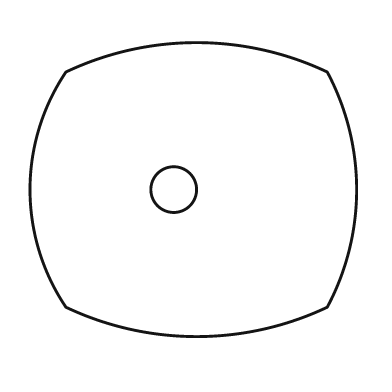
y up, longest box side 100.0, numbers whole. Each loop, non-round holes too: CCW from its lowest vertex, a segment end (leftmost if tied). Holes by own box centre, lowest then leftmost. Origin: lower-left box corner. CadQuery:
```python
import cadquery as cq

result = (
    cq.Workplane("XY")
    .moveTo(11.0, 9.0)
    .threePointArc((51.0, 0.0), (91.0, 9.0))
    .threePointArc((100.0, 45.0), (91.0, 81.0))
    .threePointArc((51.0, 90.0), (11.0, 81.0))
    .threePointArc((0.0, 45.0), (11.0, 9.0))
    .close()
    .moveTo(44.0, 45.0)
    .circle(7.0)
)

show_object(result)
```